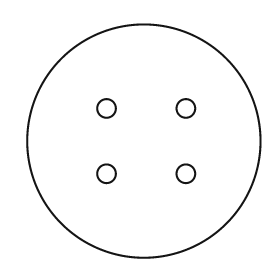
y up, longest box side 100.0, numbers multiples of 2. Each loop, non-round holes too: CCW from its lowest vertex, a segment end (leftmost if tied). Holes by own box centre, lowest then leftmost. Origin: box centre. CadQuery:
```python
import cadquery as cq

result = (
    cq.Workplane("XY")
    .moveTo(0.0, 0.0)
    .circle(50.0)
    .moveTo(-16.0, -14.0)
    .circle(4.0)
    .moveTo(18.0, -14.0)
    .circle(4.0)
    .moveTo(-16.0, 14.0)
    .circle(4.0)
    .moveTo(18.0, 14.0)
    .circle(4.0)
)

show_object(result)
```